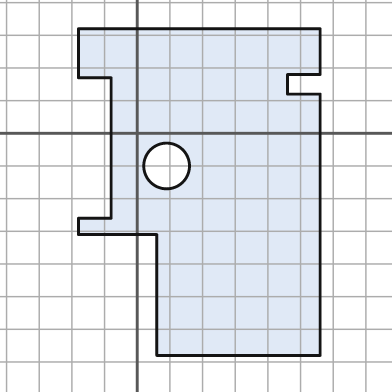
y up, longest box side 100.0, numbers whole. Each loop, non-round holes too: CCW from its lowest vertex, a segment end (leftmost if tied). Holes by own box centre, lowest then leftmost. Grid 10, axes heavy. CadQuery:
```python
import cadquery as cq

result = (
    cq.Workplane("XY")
    .moveTo(6.0, -68.0)
    .lineTo(56.0, -68.0)
    .lineTo(56.0, 12.0)
    .lineTo(46.0, 12.0)
    .lineTo(46.0, 18.0)
    .lineTo(56.0, 18.0)
    .lineTo(56.0, 32.0)
    .lineTo(-18.0, 32.0)
    .lineTo(-18.0, 17.0)
    .lineTo(-8.0, 17.0)
    .lineTo(-8.0, -26.0)
    .lineTo(-18.0, -26.0)
    .lineTo(-18.0, -31.0)
    .lineTo(6.0, -31.0)
    .close()
    .moveTo(9.0, -10.0)
    .circle(7.0)
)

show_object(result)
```